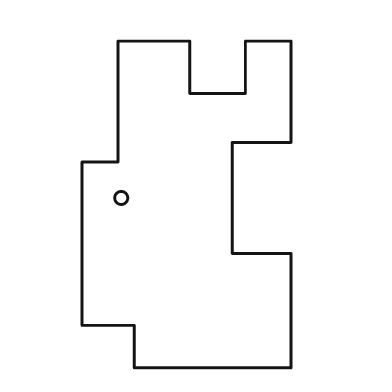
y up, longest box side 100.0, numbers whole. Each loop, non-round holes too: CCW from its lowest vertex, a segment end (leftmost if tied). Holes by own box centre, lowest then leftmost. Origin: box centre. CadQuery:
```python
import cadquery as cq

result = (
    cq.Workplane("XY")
    .moveTo(-16.0, -50.0)
    .lineTo(32.0, -50.0)
    .lineTo(32.0, -15.0)
    .lineTo(14.0, -15.0)
    .lineTo(14.0, 19.0)
    .lineTo(32.0, 19.0)
    .lineTo(32.0, 50.0)
    .lineTo(18.0, 50.0)
    .lineTo(18.0, 34.0)
    .lineTo(1.0, 34.0)
    .lineTo(1.0, 50.0)
    .lineTo(-21.0, 50.0)
    .lineTo(-21.0, 13.0)
    .lineTo(-32.0, 13.0)
    .lineTo(-32.0, -37.0)
    .lineTo(-16.0, -37.0)
    .close()
    .moveTo(-20.0, 2.0)
    .circle(2.0)
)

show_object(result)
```